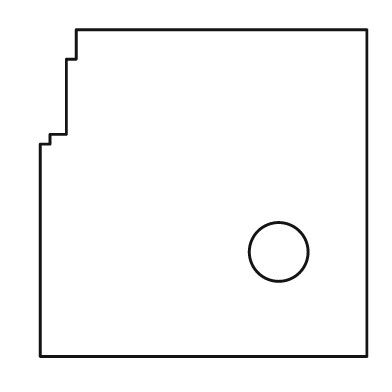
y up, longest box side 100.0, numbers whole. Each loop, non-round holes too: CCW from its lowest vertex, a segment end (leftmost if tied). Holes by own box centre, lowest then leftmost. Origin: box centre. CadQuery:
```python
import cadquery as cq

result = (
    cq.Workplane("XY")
    .moveTo(-50.0, -50.0)
    .lineTo(50.0, -50.0)
    .lineTo(50.0, 50.0)
    .lineTo(-39.0, 50.0)
    .lineTo(-39.0, 41.0)
    .lineTo(-42.0, 41.0)
    .lineTo(-42.0, 18.0)
    .lineTo(-47.0, 18.0)
    .lineTo(-47.0, 15.0)
    .lineTo(-50.0, 15.0)
    .close()
    .moveTo(23.0, -18.0)
    .circle(9.0)
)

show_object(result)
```